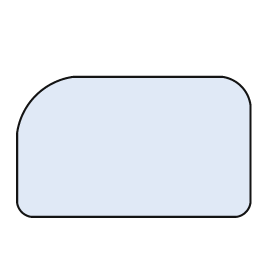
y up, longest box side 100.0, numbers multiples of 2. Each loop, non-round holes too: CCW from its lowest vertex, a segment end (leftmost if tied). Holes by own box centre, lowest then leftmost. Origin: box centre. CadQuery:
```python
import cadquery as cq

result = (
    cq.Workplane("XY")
    .moveTo(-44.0, -30.0)
    .lineTo(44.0, -30.0)
    .threePointArc((48.0, -28.0), (50.0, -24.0))
    .lineTo(50.0, 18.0)
    .threePointArc((46.0, 26.0), (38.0, 30.0))
    .lineTo(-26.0, 30.0)
    .threePointArc((-42.0, 22.0), (-50.0, 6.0))
    .lineTo(-50.0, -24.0)
    .threePointArc((-48.0, -28.0), (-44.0, -30.0))
    .close()
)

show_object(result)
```